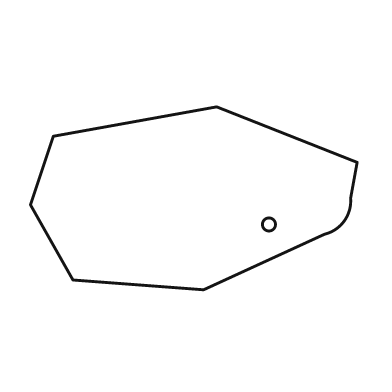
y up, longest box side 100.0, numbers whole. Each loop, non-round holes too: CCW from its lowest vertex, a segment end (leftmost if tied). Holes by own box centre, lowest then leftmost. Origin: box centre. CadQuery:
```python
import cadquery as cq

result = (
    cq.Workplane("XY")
    .moveTo(3.0, -28.0)
    .lineTo(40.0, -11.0)
    .threePointArc((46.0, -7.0), (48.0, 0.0))
    .lineTo(50.0, 11.0)
    .lineTo(7.0, 28.0)
    .lineTo(-43.0, 19.0)
    .lineTo(-50.0, -2.0)
    .lineTo(-37.0, -25.0)
    .close()
    .moveTo(23.0, -8.0)
    .circle(2.0)
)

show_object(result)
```